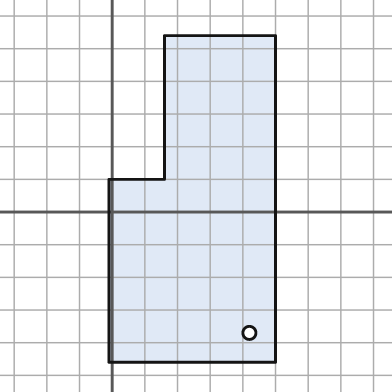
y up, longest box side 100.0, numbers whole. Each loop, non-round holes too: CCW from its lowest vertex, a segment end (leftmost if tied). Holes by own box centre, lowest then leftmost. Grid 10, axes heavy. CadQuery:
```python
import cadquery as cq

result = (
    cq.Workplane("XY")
    .moveTo(-1.0, -46.0)
    .lineTo(50.0, -46.0)
    .lineTo(50.0, 54.0)
    .lineTo(16.0, 54.0)
    .lineTo(16.0, 10.0)
    .lineTo(-1.0, 10.0)
    .close()
    .moveTo(42.0, -37.0)
    .circle(2.0)
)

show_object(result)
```